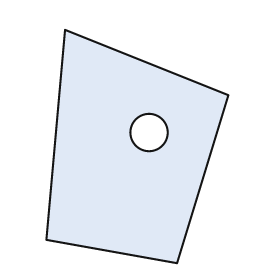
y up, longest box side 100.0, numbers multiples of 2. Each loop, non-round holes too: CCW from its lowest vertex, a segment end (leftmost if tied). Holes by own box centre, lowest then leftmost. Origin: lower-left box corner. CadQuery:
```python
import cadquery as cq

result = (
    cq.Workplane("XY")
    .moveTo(56.0, 0.0)
    .lineTo(78.0, 72.0)
    .lineTo(8.0, 100.0)
    .lineTo(0.0, 10.0)
    .close()
    .moveTo(44.0, 56.0)
    .circle(8.0)
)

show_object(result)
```